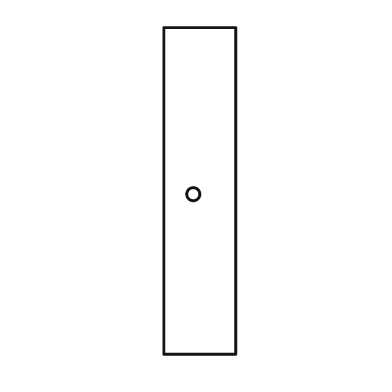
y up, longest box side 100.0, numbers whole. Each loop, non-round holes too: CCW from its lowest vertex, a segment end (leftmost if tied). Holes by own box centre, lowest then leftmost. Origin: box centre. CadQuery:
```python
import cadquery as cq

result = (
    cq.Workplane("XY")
    .moveTo(-11.0, -50.0)
    .lineTo(11.0, -50.0)
    .lineTo(11.0, 50.0)
    .lineTo(-11.0, 50.0)
    .close()
    .moveTo(-2.0, -1.0)
    .circle(2.0)
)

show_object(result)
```